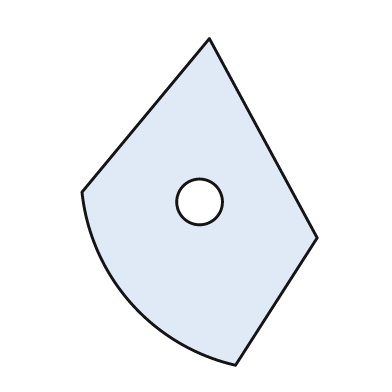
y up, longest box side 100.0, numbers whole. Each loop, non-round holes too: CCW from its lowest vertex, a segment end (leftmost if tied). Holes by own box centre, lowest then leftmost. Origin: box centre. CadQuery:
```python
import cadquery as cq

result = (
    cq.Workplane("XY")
    .moveTo(11.0, -50.0)
    .lineTo(36.0, -11.0)
    .lineTo(3.0, 50.0)
    .lineTo(-36.0, 3.0)
    .threePointArc((-21.0, -31.0), (11.0, -50.0))
    .close()
    .moveTo(0.0, 0.0)
    .circle(7.0)
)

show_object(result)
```